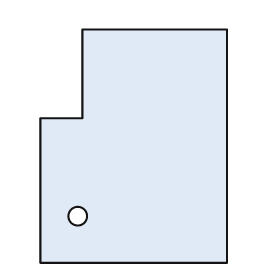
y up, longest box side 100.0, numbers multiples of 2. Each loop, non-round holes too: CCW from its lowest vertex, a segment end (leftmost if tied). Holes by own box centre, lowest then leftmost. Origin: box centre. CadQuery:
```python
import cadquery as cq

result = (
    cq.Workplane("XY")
    .moveTo(-40.0, -50.0)
    .lineTo(40.0, -50.0)
    .lineTo(40.0, 50.0)
    .lineTo(-22.0, 50.0)
    .lineTo(-22.0, 12.0)
    .lineTo(-40.0, 12.0)
    .close()
    .moveTo(-24.0, -30.0)
    .circle(4.0)
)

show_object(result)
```